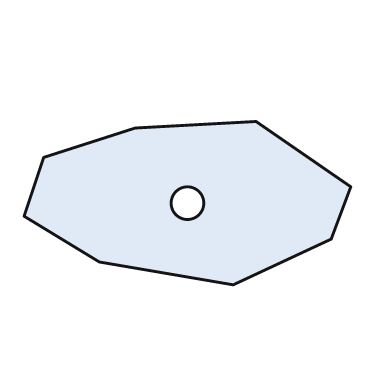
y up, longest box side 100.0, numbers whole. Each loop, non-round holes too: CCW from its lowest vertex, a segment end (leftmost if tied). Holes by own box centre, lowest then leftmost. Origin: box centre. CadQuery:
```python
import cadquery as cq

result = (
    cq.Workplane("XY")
    .moveTo(14.0, -25.0)
    .lineTo(44.0, -11.0)
    .lineTo(50.0, 5.0)
    .lineTo(21.0, 25.0)
    .lineTo(-16.0, 23.0)
    .lineTo(-44.0, 14.0)
    .lineTo(-50.0, -4.0)
    .lineTo(-27.0, -18.0)
    .close()
    .moveTo(0.0, 0.0)
    .circle(5.0)
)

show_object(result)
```